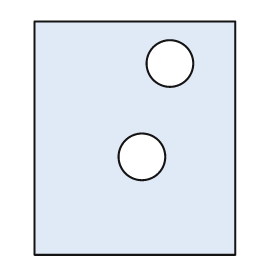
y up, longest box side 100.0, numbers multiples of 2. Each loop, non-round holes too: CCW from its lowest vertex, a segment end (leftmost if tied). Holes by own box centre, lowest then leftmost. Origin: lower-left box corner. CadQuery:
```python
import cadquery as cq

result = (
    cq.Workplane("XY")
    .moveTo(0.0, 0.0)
    .lineTo(86.0, 0.0)
    .lineTo(86.0, 100.0)
    .lineTo(0.0, 100.0)
    .close()
    .moveTo(46.0, 42.0)
    .circle(10.0)
    .moveTo(58.0, 82.0)
    .circle(10.0)
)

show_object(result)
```